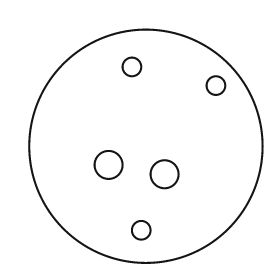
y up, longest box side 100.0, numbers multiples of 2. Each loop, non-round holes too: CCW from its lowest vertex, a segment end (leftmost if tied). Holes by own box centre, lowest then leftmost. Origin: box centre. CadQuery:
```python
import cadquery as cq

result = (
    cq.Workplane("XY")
    .moveTo(0.0, 0.0)
    .circle(50.0)
    .moveTo(-2.0, -36.0)
    .circle(4.0)
    .moveTo(8.0, -12.0)
    .circle(6.0)
    .moveTo(-16.0, -8.0)
    .circle(6.0)
    .moveTo(30.0, 26.0)
    .circle(4.0)
    .moveTo(-6.0, 34.0)
    .circle(4.0)
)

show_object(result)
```